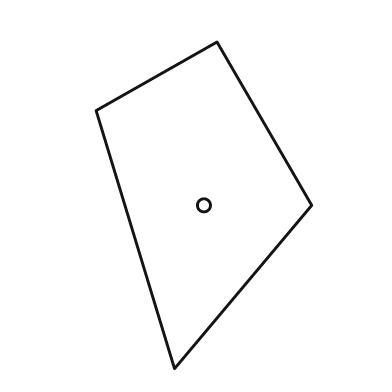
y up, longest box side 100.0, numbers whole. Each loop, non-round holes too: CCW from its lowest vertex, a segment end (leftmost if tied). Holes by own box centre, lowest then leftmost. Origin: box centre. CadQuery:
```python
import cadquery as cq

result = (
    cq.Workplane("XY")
    .moveTo(-9.0, -50.0)
    .lineTo(33.0, 0.0)
    .lineTo(4.0, 50.0)
    .lineTo(-33.0, 29.0)
    .close()
    .moveTo(0.0, 0.0)
    .circle(2.0)
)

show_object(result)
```